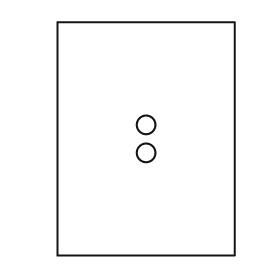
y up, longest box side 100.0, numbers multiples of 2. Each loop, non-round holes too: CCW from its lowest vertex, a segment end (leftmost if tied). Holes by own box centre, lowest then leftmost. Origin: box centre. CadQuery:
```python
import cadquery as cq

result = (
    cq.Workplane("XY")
    .moveTo(-38.0, -50.0)
    .lineTo(38.0, -50.0)
    .lineTo(38.0, 50.0)
    .lineTo(-38.0, 50.0)
    .close()
    .moveTo(0.0, -6.0)
    .circle(4.0)
    .moveTo(0.0, 6.0)
    .circle(4.0)
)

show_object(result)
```